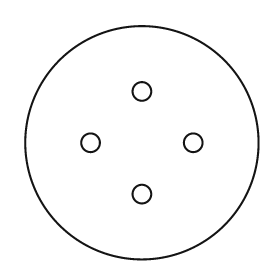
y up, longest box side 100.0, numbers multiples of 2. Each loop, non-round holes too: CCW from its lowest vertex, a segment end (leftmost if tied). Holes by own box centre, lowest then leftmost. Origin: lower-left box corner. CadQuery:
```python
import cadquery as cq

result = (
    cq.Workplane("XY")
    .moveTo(50.0, 50.0)
    .circle(50.0)
    .moveTo(50.0, 28.0)
    .circle(4.0)
    .moveTo(28.0, 50.0)
    .circle(4.0)
    .moveTo(72.0, 50.0)
    .circle(4.0)
    .moveTo(50.0, 72.0)
    .circle(4.0)
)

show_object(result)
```